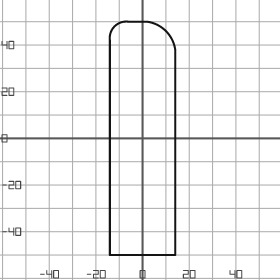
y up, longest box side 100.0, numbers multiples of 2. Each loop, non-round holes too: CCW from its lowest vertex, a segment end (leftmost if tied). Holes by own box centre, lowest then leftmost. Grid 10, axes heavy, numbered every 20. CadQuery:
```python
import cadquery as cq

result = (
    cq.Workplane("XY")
    .moveTo(-14.0, -50.0)
    .lineTo(14.0, -50.0)
    .lineTo(14.0, 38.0)
    .threePointArc((10.0, 46.0), (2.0, 50.0))
    .lineTo(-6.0, 50.0)
    .threePointArc((-12.0, 48.0), (-14.0, 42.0))
    .close()
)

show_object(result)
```